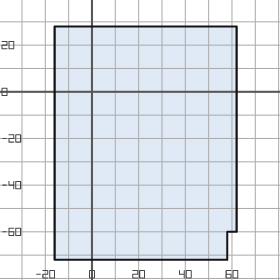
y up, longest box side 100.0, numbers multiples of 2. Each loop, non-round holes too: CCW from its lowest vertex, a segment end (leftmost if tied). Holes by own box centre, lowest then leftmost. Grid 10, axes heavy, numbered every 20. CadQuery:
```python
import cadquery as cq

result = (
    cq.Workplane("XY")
    .moveTo(-16.0, -72.0)
    .lineTo(58.0, -72.0)
    .lineTo(58.0, -60.0)
    .lineTo(62.0, -60.0)
    .lineTo(62.0, 28.0)
    .lineTo(-16.0, 28.0)
    .close()
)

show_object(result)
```